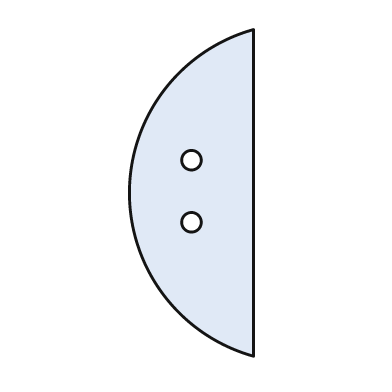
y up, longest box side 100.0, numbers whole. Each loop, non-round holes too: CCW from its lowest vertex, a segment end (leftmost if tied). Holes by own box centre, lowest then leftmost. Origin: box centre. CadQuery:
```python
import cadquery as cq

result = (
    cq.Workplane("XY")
    .moveTo(19.0, -50.0)
    .lineTo(19.0, 50.0)
    .threePointArc((-19.0, 0.0), (19.0, -50.0))
    .close()
    .moveTo(0.0, -9.0)
    .circle(3.0)
    .moveTo(0.0, 10.0)
    .circle(3.0)
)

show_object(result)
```